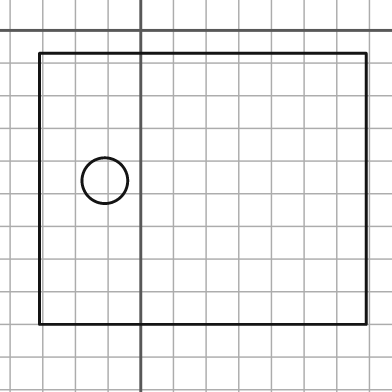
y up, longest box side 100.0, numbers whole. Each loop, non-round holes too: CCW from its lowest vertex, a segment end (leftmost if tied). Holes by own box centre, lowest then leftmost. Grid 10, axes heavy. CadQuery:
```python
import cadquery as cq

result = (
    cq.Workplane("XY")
    .moveTo(-31.0, -90.0)
    .lineTo(69.0, -90.0)
    .lineTo(69.0, -7.0)
    .lineTo(-31.0, -7.0)
    .close()
    .moveTo(-11.0, -46.0)
    .circle(7.0)
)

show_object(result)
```